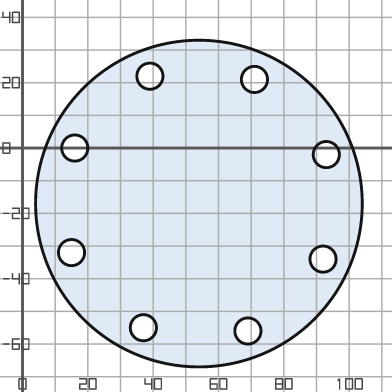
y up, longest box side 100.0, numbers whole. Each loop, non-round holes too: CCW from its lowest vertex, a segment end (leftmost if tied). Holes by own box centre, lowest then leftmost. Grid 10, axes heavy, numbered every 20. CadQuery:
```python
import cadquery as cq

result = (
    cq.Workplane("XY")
    .moveTo(54.0, -17.0)
    .circle(50.0)
    .moveTo(69.0, -56.0)
    .circle(4.0)
    .moveTo(37.0, -55.0)
    .circle(4.0)
    .moveTo(92.0, -34.0)
    .circle(4.0)
    .moveTo(15.0, -32.0)
    .circle(4.0)
    .moveTo(93.0, -2.0)
    .circle(4.0)
    .moveTo(16.0, 0.0)
    .circle(4.0)
    .moveTo(71.0, 21.0)
    .circle(4.0)
    .moveTo(39.0, 22.0)
    .circle(4.0)
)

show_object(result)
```